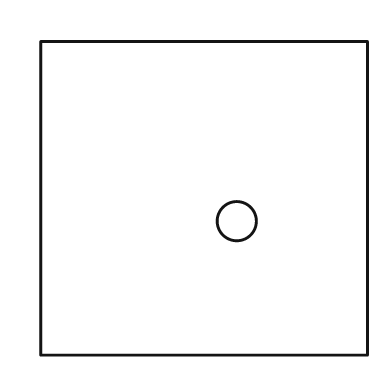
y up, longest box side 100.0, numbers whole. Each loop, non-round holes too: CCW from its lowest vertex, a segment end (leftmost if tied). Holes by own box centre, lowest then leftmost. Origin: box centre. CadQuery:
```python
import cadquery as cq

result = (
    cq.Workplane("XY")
    .moveTo(-50.0, -48.0)
    .lineTo(50.0, -48.0)
    .lineTo(50.0, 48.0)
    .lineTo(-50.0, 48.0)
    .close()
    .moveTo(10.0, -7.0)
    .circle(6.0)
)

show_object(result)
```